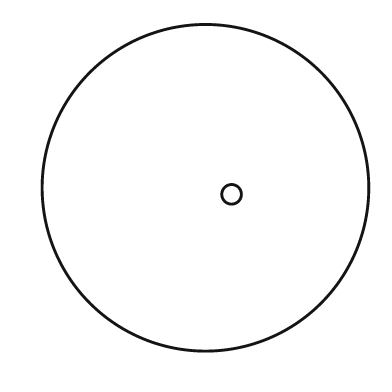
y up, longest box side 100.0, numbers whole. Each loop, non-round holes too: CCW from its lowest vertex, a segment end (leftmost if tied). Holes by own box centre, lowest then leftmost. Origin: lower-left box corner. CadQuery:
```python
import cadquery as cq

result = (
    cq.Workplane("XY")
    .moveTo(50.0, 50.0)
    .circle(50.0)
    .moveTo(58.0, 48.0)
    .circle(3.0)
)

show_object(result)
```